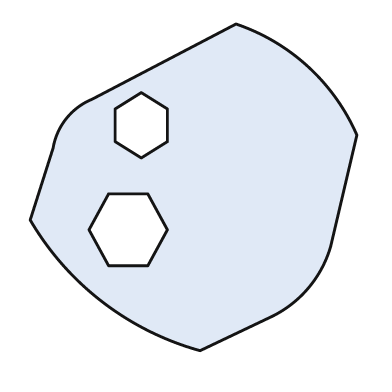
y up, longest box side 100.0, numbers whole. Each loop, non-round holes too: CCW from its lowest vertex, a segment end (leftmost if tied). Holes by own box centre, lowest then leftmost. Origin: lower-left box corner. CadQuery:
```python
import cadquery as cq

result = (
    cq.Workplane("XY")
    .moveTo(52.0, 0.0)
    .lineTo(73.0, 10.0)
    .threePointArc((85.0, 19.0), (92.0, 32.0))
    .lineTo(100.0, 66.0)
    .threePointArc((85.0, 87.0), (63.0, 100.0))
    .lineTo(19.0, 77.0)
    .threePointArc((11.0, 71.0), (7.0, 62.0))
    .lineTo(0.0, 40.0)
    .threePointArc((22.0, 15.0), (52.0, 0.0))
    .close()
    .moveTo(24.0, 26.0)
    .lineTo(36.0, 26.0)
    .lineTo(42.0, 37.0)
    .lineTo(36.0, 48.0)
    .lineTo(24.0, 48.0)
    .lineTo(18.0, 37.0)
    .close()
    .moveTo(34.0, 59.0)
    .lineTo(42.0, 64.0)
    .lineTo(42.0, 74.0)
    .lineTo(34.0, 79.0)
    .lineTo(26.0, 74.0)
    .lineTo(26.0, 64.0)
    .close()
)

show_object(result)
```